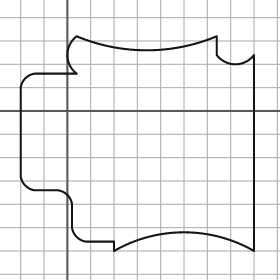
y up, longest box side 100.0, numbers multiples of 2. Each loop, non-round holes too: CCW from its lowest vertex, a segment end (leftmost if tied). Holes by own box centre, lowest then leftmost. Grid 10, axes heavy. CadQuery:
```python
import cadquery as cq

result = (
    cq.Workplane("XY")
    .moveTo(20.0, -60.0)
    .threePointArc((50.0, -52.0), (80.0, -60.0))
    .lineTo(80.0, 24.0)
    .threePointArc((72.0, 20.0), (64.0, 24.0))
    .lineTo(64.0, 32.0)
    .threePointArc((34.0, 26.0), (4.0, 32.0))
    .threePointArc((0.0, 24.0), (4.0, 16.0))
    .lineTo(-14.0, 16.0)
    .threePointArc((-18.0, 14.0), (-20.0, 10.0))
    .lineTo(-20.0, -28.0)
    .threePointArc((-18.0, -32.0), (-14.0, -34.0))
    .lineTo(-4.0, -34.0)
    .threePointArc((0.0, -36.0), (2.0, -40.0))
    .lineTo(2.0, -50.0)
    .threePointArc((4.0, -54.0), (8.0, -56.0))
    .lineTo(20.0, -56.0)
    .close()
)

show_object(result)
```